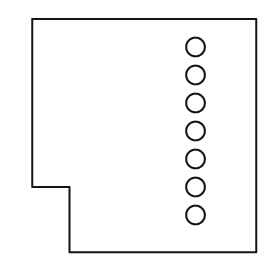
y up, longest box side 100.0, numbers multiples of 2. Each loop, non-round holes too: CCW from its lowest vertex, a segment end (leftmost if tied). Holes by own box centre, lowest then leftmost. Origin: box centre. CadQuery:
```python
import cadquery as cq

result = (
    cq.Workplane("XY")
    .moveTo(-32.0, -50.0)
    .lineTo(48.0, -50.0)
    .lineTo(48.0, 50.0)
    .lineTo(-48.0, 50.0)
    .lineTo(-48.0, -22.0)
    .lineTo(-32.0, -22.0)
    .close()
    .moveTo(22.0, -34.0)
    .circle(4.0)
    .moveTo(22.0, -22.0)
    .circle(4.0)
    .moveTo(22.0, -10.0)
    .circle(4.0)
    .moveTo(22.0, 2.0)
    .circle(4.0)
    .moveTo(22.0, 14.0)
    .circle(4.0)
    .moveTo(22.0, 26.0)
    .circle(4.0)
    .moveTo(22.0, 38.0)
    .circle(4.0)
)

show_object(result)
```